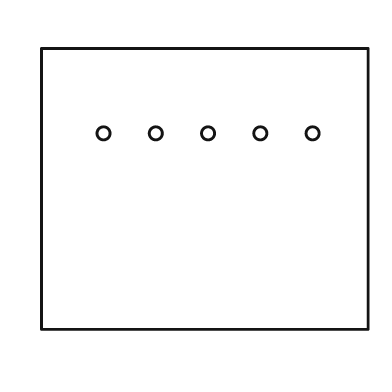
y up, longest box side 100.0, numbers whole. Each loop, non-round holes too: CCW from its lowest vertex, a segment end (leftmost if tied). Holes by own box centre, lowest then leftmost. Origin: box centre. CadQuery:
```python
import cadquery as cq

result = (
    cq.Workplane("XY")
    .moveTo(-50.0, -43.0)
    .lineTo(50.0, -43.0)
    .lineTo(50.0, 43.0)
    .lineTo(-50.0, 43.0)
    .close()
    .moveTo(-31.0, 17.0)
    .circle(2.0)
    .moveTo(-15.0, 17.0)
    .circle(2.0)
    .moveTo(1.0, 17.0)
    .circle(2.0)
    .moveTo(17.0, 17.0)
    .circle(2.0)
    .moveTo(33.0, 17.0)
    .circle(2.0)
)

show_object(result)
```